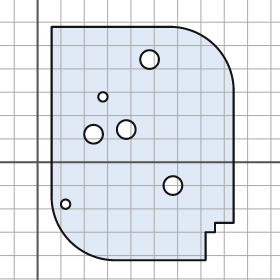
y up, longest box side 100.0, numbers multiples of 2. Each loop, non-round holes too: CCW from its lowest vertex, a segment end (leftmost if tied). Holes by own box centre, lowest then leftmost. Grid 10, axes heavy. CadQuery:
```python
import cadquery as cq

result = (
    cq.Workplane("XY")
    .moveTo(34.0, -42.0)
    .lineTo(72.0, -42.0)
    .lineTo(72.0, -30.0)
    .lineTo(76.0, -30.0)
    .lineTo(76.0, -26.0)
    .lineTo(84.0, -26.0)
    .lineTo(84.0, 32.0)
    .threePointArc((76.0, 50.0), (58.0, 58.0))
    .lineTo(6.0, 58.0)
    .lineTo(6.0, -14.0)
    .threePointArc((14.0, -34.0), (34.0, -42.0))
    .close()
    .moveTo(12.0, -18.0)
    .circle(2.0)
    .moveTo(58.0, -10.0)
    .circle(4.0)
    .moveTo(24.0, 12.0)
    .circle(4.0)
    .moveTo(38.0, 14.0)
    .circle(4.0)
    .moveTo(28.0, 28.0)
    .circle(2.0)
    .moveTo(48.0, 44.0)
    .circle(4.0)
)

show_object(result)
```